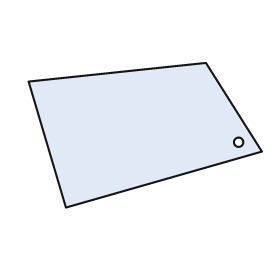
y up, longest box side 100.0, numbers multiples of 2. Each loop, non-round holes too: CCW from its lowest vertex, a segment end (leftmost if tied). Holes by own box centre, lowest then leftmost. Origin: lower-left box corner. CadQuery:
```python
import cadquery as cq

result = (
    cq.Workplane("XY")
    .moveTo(16.0, 0.0)
    .lineTo(100.0, 24.0)
    .lineTo(76.0, 62.0)
    .lineTo(0.0, 54.0)
    .close()
    .moveTo(90.0, 28.0)
    .circle(2.0)
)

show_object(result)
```